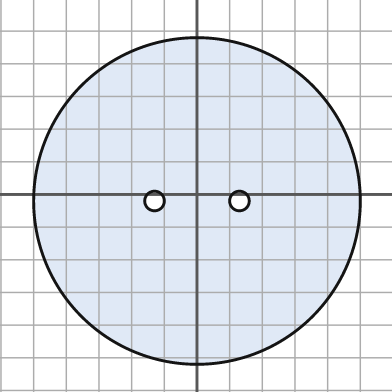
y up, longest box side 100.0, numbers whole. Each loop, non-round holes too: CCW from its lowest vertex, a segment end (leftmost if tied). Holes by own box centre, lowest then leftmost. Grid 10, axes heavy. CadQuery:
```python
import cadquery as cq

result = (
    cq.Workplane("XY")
    .moveTo(0.0, -2.0)
    .circle(50.0)
    .moveTo(-13.0, -2.0)
    .circle(3.0)
    .moveTo(13.0, -2.0)
    .circle(3.0)
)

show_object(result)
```